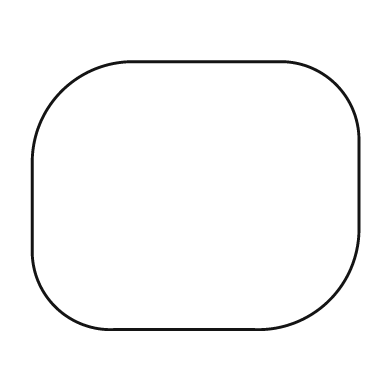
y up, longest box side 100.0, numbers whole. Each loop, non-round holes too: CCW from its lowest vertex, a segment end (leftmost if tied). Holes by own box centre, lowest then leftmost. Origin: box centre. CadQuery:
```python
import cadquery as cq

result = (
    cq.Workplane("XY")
    .moveTo(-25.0, -41.0)
    .lineTo(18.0, -41.0)
    .threePointArc((41.0, -32.0), (50.0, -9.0))
    .lineTo(50.0, 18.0)
    .threePointArc((43.0, 34.0), (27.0, 41.0))
    .lineTo(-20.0, 41.0)
    .threePointArc((-41.0, 32.0), (-50.0, 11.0))
    .lineTo(-50.0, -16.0)
    .threePointArc((-43.0, -34.0), (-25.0, -41.0))
    .close()
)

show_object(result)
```